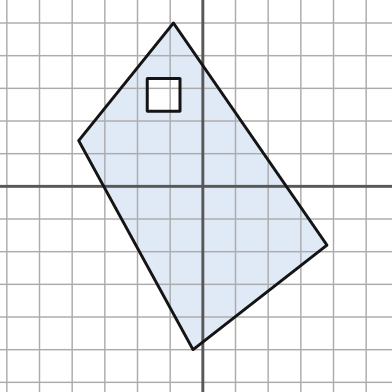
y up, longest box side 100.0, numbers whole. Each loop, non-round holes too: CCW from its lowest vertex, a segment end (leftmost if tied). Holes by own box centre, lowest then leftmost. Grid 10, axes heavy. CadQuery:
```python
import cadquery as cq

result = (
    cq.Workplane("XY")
    .moveTo(-3.0, -50.0)
    .lineTo(38.0, -18.0)
    .lineTo(-9.0, 50.0)
    .lineTo(-38.0, 14.0)
    .close()
    .moveTo(-17.0, 23.0)
    .lineTo(-7.0, 23.0)
    .lineTo(-7.0, 33.0)
    .lineTo(-17.0, 33.0)
    .close()
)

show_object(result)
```